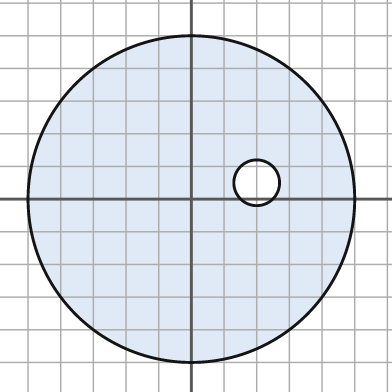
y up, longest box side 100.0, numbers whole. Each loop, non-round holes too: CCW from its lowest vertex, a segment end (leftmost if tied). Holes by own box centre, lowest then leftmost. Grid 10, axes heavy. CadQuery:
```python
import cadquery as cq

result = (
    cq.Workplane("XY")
    .moveTo(0.0, 0.0)
    .circle(50.0)
    .moveTo(20.0, 5.0)
    .circle(7.0)
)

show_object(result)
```